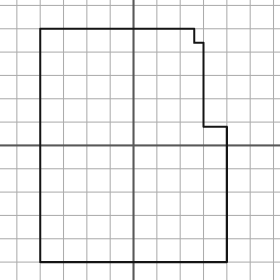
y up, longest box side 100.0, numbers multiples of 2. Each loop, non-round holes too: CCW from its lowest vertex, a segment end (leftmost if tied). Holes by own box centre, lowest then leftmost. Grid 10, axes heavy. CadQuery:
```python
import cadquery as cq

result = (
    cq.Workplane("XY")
    .moveTo(-40.0, -50.0)
    .lineTo(40.0, -50.0)
    .lineTo(40.0, 8.0)
    .lineTo(30.0, 8.0)
    .lineTo(30.0, 44.0)
    .lineTo(26.0, 44.0)
    .lineTo(26.0, 50.0)
    .lineTo(-40.0, 50.0)
    .close()
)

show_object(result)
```